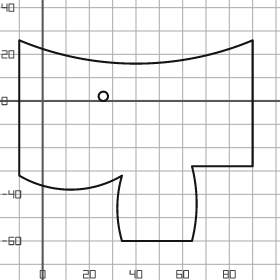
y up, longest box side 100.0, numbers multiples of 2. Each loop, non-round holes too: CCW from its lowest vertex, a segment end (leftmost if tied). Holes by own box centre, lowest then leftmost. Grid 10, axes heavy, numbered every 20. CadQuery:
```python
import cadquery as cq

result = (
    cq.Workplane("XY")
    .moveTo(34.0, -60.0)
    .lineTo(64.0, -60.0)
    .threePointArc((66.0, -44.0), (64.0, -28.0))
    .lineTo(90.0, -28.0)
    .lineTo(90.0, 26.0)
    .threePointArc((40.0, 16.0), (-10.0, 26.0))
    .lineTo(-10.0, -32.0)
    .threePointArc((12.0, -38.0), (34.0, -32.0))
    .threePointArc((32.0, -46.0), (34.0, -60.0))
    .close()
    .moveTo(26.0, 2.0)
    .circle(2.0)
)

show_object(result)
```